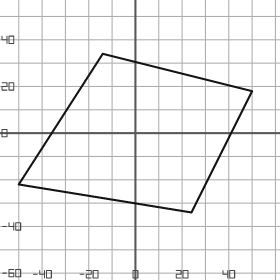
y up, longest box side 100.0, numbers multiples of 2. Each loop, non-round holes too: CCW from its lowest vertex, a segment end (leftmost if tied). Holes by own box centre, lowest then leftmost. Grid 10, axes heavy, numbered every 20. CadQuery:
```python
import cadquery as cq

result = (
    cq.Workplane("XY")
    .moveTo(24.0, -34.0)
    .lineTo(50.0, 18.0)
    .lineTo(-14.0, 34.0)
    .lineTo(-50.0, -22.0)
    .close()
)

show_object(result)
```